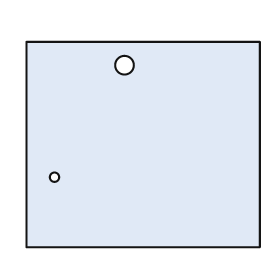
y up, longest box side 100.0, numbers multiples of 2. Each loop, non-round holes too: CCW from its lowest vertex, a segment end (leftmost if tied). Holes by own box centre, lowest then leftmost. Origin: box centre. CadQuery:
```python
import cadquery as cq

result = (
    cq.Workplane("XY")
    .moveTo(-50.0, -44.0)
    .lineTo(50.0, -44.0)
    .lineTo(50.0, 44.0)
    .lineTo(-50.0, 44.0)
    .close()
    .moveTo(-38.0, -14.0)
    .circle(2.0)
    .moveTo(-8.0, 34.0)
    .circle(4.0)
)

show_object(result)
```